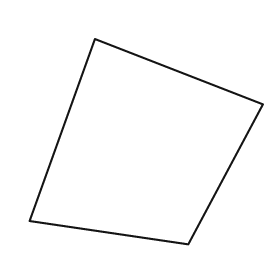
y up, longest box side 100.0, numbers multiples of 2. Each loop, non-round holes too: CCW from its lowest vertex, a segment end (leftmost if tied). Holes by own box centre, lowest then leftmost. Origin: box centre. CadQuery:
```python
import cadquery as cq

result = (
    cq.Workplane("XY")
    .moveTo(18.0, -44.0)
    .lineTo(50.0, 16.0)
    .lineTo(-22.0, 44.0)
    .lineTo(-50.0, -34.0)
    .close()
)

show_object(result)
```